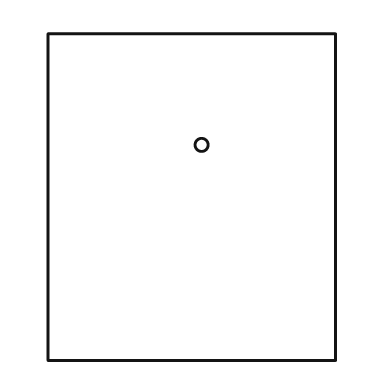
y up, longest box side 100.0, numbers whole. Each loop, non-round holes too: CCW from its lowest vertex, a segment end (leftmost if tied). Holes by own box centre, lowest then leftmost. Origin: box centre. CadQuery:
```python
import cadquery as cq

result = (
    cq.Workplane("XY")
    .moveTo(-44.0, -50.0)
    .lineTo(44.0, -50.0)
    .lineTo(44.0, 50.0)
    .lineTo(-44.0, 50.0)
    .close()
    .moveTo(3.0, 16.0)
    .circle(2.0)
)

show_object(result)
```